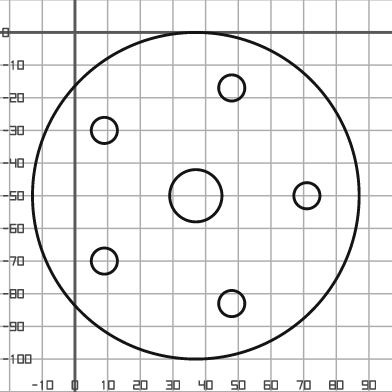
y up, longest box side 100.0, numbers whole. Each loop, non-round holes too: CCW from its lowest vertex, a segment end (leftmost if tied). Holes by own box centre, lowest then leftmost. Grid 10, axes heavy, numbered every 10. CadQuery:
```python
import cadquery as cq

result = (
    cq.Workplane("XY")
    .moveTo(37.0, -50.0)
    .circle(50.0)
    .moveTo(48.0, -83.0)
    .circle(4.0)
    .moveTo(9.0, -70.0)
    .circle(4.0)
    .moveTo(37.0, -50.0)
    .circle(8.0)
    .moveTo(71.0, -50.0)
    .circle(4.0)
    .moveTo(9.0, -30.0)
    .circle(4.0)
    .moveTo(48.0, -17.0)
    .circle(4.0)
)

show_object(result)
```